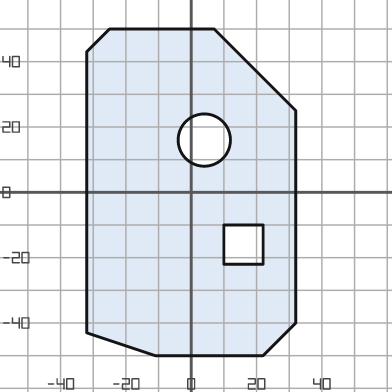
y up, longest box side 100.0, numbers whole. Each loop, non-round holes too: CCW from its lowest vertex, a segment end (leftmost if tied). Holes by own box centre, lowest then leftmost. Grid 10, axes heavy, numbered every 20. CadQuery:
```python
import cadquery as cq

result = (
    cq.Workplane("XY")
    .moveTo(-11.0, -50.0)
    .lineTo(22.0, -50.0)
    .lineTo(32.0, -40.0)
    .lineTo(32.0, 25.0)
    .lineTo(7.0, 50.0)
    .lineTo(-25.0, 50.0)
    .lineTo(-32.0, 43.0)
    .lineTo(-32.0, -43.0)
    .close()
    .moveTo(10.0, -22.0)
    .lineTo(22.0, -22.0)
    .lineTo(22.0, -10.0)
    .lineTo(10.0, -10.0)
    .close()
    .moveTo(4.0, 16.0)
    .circle(8.0)
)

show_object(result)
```